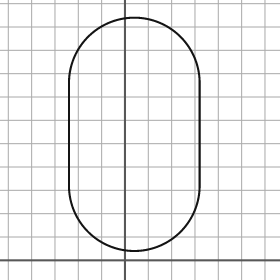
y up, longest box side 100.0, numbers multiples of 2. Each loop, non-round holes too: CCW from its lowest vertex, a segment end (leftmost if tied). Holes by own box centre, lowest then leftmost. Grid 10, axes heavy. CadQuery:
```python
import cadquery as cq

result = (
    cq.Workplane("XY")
    .moveTo(-24.0, 32.0)
    .threePointArc((4.0, 4.0), (32.0, 32.0))
    .lineTo(32.0, 76.0)
    .threePointArc((4.0, 104.0), (-24.0, 76.0))
    .close()
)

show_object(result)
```